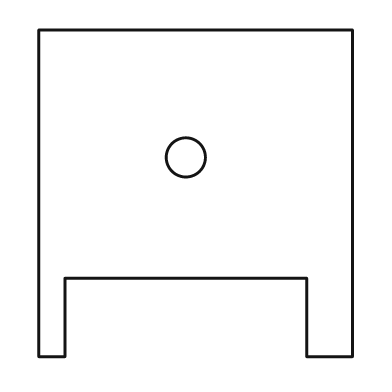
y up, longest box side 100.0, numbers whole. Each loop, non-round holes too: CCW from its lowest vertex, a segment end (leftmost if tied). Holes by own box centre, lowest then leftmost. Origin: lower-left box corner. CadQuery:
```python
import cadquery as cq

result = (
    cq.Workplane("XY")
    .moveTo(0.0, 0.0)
    .lineTo(8.0, 0.0)
    .lineTo(8.0, 24.0)
    .lineTo(82.0, 24.0)
    .lineTo(82.0, 0.0)
    .lineTo(96.0, 0.0)
    .lineTo(96.0, 100.0)
    .lineTo(0.0, 100.0)
    .close()
    .moveTo(45.0, 61.0)
    .circle(6.0)
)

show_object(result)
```